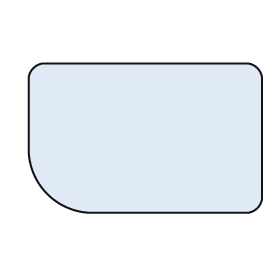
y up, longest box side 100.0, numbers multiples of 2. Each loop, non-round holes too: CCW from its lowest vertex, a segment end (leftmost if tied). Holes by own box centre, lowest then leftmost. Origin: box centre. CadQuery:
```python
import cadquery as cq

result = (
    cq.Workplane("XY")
    .moveTo(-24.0, -32.0)
    .lineTo(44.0, -32.0)
    .threePointArc((48.0, -30.0), (50.0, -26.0))
    .lineTo(50.0, 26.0)
    .threePointArc((48.0, 30.0), (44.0, 32.0))
    .lineTo(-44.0, 32.0)
    .threePointArc((-48.0, 30.0), (-50.0, 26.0))
    .lineTo(-50.0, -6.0)
    .threePointArc((-42.0, -24.0), (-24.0, -32.0))
    .close()
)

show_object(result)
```